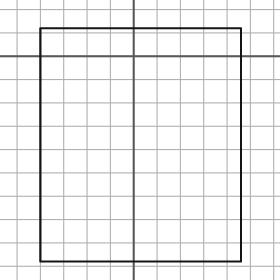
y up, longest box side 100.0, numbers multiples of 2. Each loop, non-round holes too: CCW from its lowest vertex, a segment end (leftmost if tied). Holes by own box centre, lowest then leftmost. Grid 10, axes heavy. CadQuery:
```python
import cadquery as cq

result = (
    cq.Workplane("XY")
    .moveTo(-40.0, -88.0)
    .lineTo(46.0, -88.0)
    .lineTo(46.0, 12.0)
    .lineTo(-40.0, 12.0)
    .close()
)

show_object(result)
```